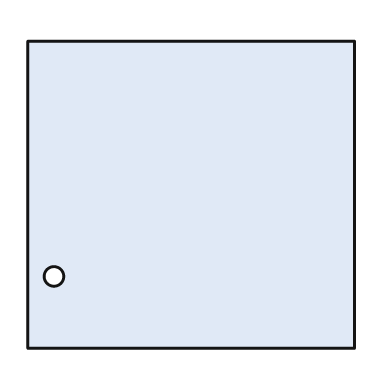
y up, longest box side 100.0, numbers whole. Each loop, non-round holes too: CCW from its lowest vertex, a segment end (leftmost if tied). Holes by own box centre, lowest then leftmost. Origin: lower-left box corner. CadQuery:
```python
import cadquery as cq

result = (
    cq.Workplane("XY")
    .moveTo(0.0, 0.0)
    .lineTo(100.0, 0.0)
    .lineTo(100.0, 94.0)
    .lineTo(0.0, 94.0)
    .close()
    .moveTo(8.0, 22.0)
    .circle(3.0)
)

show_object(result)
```